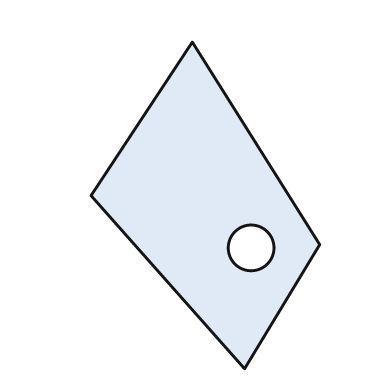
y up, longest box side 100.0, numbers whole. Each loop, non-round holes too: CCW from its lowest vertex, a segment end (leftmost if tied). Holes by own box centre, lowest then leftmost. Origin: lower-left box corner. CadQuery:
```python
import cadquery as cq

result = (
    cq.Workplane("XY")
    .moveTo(47.0, 0.0)
    .lineTo(70.0, 38.0)
    .lineTo(31.0, 100.0)
    .lineTo(0.0, 53.0)
    .close()
    .moveTo(49.0, 37.0)
    .circle(7.0)
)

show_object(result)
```